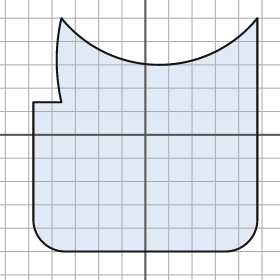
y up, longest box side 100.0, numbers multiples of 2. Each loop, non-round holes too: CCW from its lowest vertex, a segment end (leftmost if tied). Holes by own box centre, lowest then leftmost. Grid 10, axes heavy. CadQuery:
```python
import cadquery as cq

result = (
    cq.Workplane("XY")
    .moveTo(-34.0, -50.0)
    .lineTo(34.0, -50.0)
    .threePointArc((44.0, -46.0), (48.0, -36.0))
    .lineTo(48.0, 50.0)
    .threePointArc((6.0, 30.0), (-36.0, 50.0))
    .threePointArc((-38.0, 32.0), (-36.0, 14.0))
    .lineTo(-48.0, 14.0)
    .lineTo(-48.0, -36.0)
    .threePointArc((-44.0, -46.0), (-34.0, -50.0))
    .close()
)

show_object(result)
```